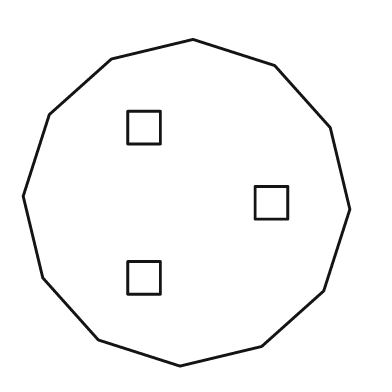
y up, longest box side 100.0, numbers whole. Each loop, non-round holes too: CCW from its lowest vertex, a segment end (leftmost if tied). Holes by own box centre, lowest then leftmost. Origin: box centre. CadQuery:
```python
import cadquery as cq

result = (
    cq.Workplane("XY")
    .moveTo(-2.0, -50.0)
    .lineTo(23.0, -44.0)
    .lineTo(42.0, -27.0)
    .lineTo(50.0, -2.0)
    .lineTo(44.0, 23.0)
    .lineTo(27.0, 42.0)
    .lineTo(2.0, 50.0)
    .lineTo(-23.0, 44.0)
    .lineTo(-42.0, 27.0)
    .lineTo(-50.0, 2.0)
    .lineTo(-44.0, -23.0)
    .lineTo(-27.0, -42.0)
    .close()
    .moveTo(-18.0, -28.0)
    .lineTo(-8.0, -28.0)
    .lineTo(-8.0, -18.0)
    .lineTo(-18.0, -18.0)
    .close()
    .moveTo(21.0, -5.0)
    .lineTo(31.0, -5.0)
    .lineTo(31.0, 5.0)
    .lineTo(21.0, 5.0)
    .close()
    .moveTo(-18.0, 18.0)
    .lineTo(-8.0, 18.0)
    .lineTo(-8.0, 28.0)
    .lineTo(-18.0, 28.0)
    .close()
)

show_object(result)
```